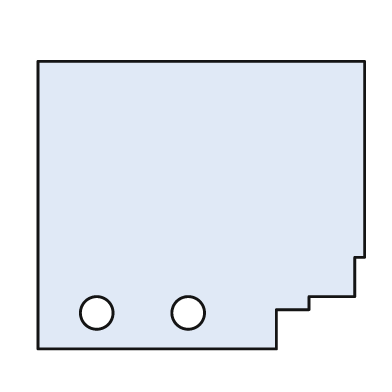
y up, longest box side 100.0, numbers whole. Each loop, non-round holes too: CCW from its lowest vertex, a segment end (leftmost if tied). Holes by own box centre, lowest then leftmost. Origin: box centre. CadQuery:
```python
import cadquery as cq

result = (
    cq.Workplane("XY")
    .moveTo(-50.0, -44.0)
    .lineTo(23.0, -44.0)
    .lineTo(23.0, -32.0)
    .lineTo(33.0, -32.0)
    .lineTo(33.0, -28.0)
    .lineTo(47.0, -28.0)
    .lineTo(47.0, -16.0)
    .lineTo(50.0, -16.0)
    .lineTo(50.0, 44.0)
    .lineTo(-50.0, 44.0)
    .close()
    .moveTo(-32.0, -33.0)
    .circle(5.0)
    .moveTo(-4.0, -33.0)
    .circle(5.0)
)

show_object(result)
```